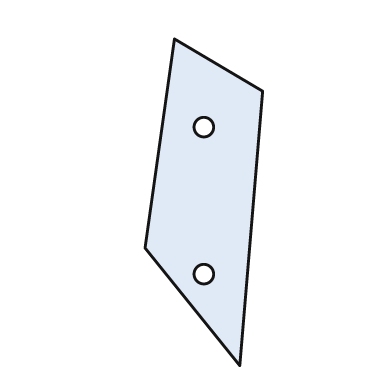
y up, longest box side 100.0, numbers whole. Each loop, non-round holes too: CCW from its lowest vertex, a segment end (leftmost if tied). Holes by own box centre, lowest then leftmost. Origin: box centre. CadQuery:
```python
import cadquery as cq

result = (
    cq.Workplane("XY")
    .moveTo(11.0, -50.0)
    .lineTo(18.0, 34.0)
    .lineTo(-9.0, 50.0)
    .lineTo(-18.0, -14.0)
    .close()
    .moveTo(0.0, -22.0)
    .circle(3.0)
    .moveTo(0.0, 23.0)
    .circle(3.0)
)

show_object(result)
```